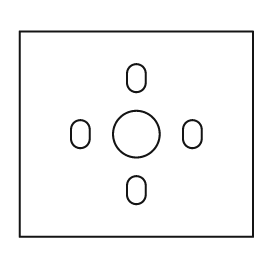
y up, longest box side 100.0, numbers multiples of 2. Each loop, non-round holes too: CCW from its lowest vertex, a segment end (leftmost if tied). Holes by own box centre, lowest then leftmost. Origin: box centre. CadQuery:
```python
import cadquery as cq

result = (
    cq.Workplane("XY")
    .moveTo(-50.0, -44.0)
    .lineTo(50.0, -44.0)
    .lineTo(50.0, 44.0)
    .lineTo(-50.0, 44.0)
    .close()
    .moveTo(-4.0, -26.0)
    .threePointArc((0.0, -30.0), (4.0, -26.0))
    .lineTo(4.0, -22.0)
    .threePointArc((0.0, -18.0), (-4.0, -22.0))
    .close()
    .moveTo(-28.0, -2.0)
    .threePointArc((-24.0, -6.0), (-20.0, -2.0))
    .lineTo(-20.0, 2.0)
    .threePointArc((-24.0, 6.0), (-28.0, 2.0))
    .close()
    .moveTo(0.0, 0.0)
    .circle(10.0)
    .moveTo(20.0, -2.0)
    .threePointArc((24.0, -6.0), (28.0, -2.0))
    .lineTo(28.0, 2.0)
    .threePointArc((24.0, 6.0), (20.0, 2.0))
    .close()
    .moveTo(-4.0, 22.0)
    .threePointArc((0.0, 18.0), (4.0, 22.0))
    .lineTo(4.0, 26.0)
    .threePointArc((0.0, 30.0), (-4.0, 26.0))
    .close()
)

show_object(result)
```